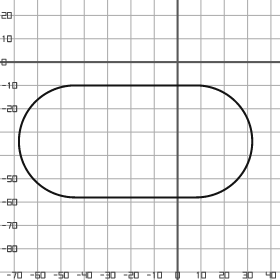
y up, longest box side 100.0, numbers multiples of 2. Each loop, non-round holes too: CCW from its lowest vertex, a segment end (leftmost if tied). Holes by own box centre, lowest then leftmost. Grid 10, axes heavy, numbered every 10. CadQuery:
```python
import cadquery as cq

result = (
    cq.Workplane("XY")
    .moveTo(-44.0, -58.0)
    .lineTo(8.0, -58.0)
    .threePointArc((32.0, -34.0), (8.0, -10.0))
    .lineTo(-44.0, -10.0)
    .threePointArc((-68.0, -34.0), (-44.0, -58.0))
    .close()
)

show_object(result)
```